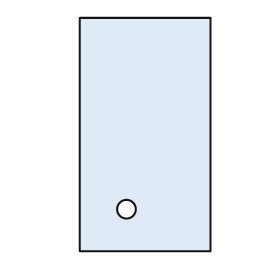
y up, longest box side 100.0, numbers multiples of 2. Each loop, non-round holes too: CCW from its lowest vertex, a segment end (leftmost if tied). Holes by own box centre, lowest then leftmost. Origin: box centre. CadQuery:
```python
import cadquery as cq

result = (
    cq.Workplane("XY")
    .moveTo(-28.0, -50.0)
    .lineTo(28.0, -50.0)
    .lineTo(28.0, 50.0)
    .lineTo(-28.0, 50.0)
    .close()
    .moveTo(-8.0, -32.0)
    .circle(4.0)
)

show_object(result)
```